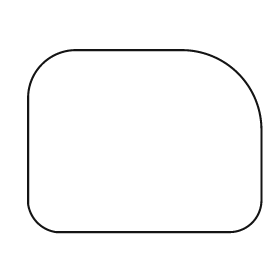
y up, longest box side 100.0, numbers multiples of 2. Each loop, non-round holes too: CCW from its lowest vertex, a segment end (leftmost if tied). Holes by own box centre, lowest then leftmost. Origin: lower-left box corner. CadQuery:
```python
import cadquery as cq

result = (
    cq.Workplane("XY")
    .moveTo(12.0, 0.0)
    .lineTo(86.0, 0.0)
    .threePointArc((96.0, 4.0), (100.0, 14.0))
    .lineTo(100.0, 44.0)
    .threePointArc((90.0, 68.0), (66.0, 78.0))
    .lineTo(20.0, 78.0)
    .threePointArc((6.0, 72.0), (0.0, 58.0))
    .lineTo(0.0, 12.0)
    .threePointArc((4.0, 4.0), (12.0, 0.0))
    .close()
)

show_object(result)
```